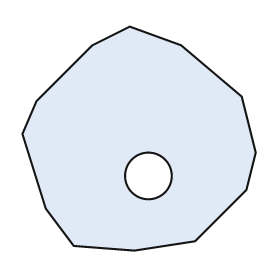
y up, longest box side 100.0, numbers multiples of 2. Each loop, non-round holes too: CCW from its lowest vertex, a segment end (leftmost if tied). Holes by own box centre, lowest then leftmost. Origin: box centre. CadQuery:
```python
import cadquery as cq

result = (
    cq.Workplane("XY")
    .moveTo(-2.0, -48.0)
    .lineTo(24.0, -44.0)
    .lineTo(46.0, -22.0)
    .lineTo(50.0, -6.0)
    .lineTo(44.0, 18.0)
    .lineTo(18.0, 40.0)
    .lineTo(-4.0, 48.0)
    .lineTo(-20.0, 40.0)
    .lineTo(-44.0, 16.0)
    .lineTo(-50.0, 2.0)
    .lineTo(-40.0, -30.0)
    .lineTo(-28.0, -46.0)
    .close()
    .moveTo(4.0, -16.0)
    .circle(10.0)
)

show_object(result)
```